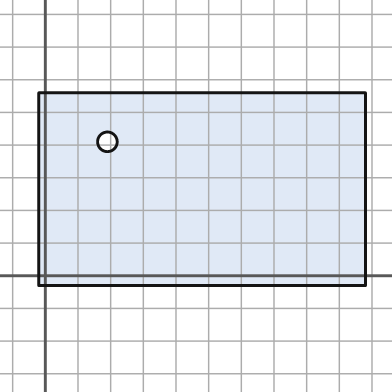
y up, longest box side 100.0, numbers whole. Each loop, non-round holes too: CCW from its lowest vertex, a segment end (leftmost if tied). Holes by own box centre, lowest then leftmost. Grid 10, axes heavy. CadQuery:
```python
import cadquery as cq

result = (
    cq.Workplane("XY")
    .moveTo(-2.0, -3.0)
    .lineTo(98.0, -3.0)
    .lineTo(98.0, 56.0)
    .lineTo(-2.0, 56.0)
    .close()
    .moveTo(19.0, 41.0)
    .circle(3.0)
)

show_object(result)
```